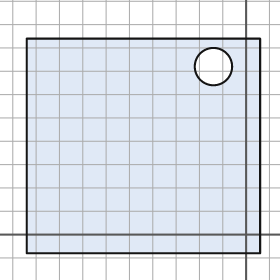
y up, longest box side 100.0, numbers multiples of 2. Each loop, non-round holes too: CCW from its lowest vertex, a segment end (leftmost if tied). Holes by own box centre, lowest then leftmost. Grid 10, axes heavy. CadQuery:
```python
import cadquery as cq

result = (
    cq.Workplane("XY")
    .moveTo(-94.0, -8.0)
    .lineTo(6.0, -8.0)
    .lineTo(6.0, 84.0)
    .lineTo(-94.0, 84.0)
    .close()
    .moveTo(-14.0, 72.0)
    .circle(8.0)
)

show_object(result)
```